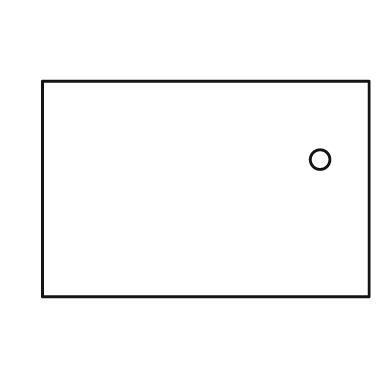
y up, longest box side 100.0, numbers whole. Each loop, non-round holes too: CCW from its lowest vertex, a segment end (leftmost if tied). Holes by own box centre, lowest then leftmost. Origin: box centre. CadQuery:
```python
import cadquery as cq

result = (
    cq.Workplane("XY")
    .moveTo(-50.0, -33.0)
    .lineTo(50.0, -33.0)
    .lineTo(50.0, 33.0)
    .lineTo(-50.0, 33.0)
    .close()
    .moveTo(35.0, 9.0)
    .circle(3.0)
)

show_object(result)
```